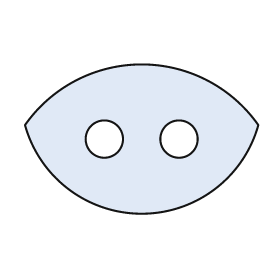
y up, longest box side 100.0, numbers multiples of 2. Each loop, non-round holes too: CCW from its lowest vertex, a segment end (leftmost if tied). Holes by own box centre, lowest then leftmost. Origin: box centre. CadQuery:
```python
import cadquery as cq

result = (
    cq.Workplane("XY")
    .moveTo(-50.0, 6.0)
    .threePointArc((0.0, -32.0), (50.0, 6.0))
    .threePointArc((0.0, 32.0), (-50.0, 6.0))
    .close()
    .moveTo(-16.0, 0.0)
    .circle(8.0)
    .moveTo(16.0, 0.0)
    .circle(8.0)
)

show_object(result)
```